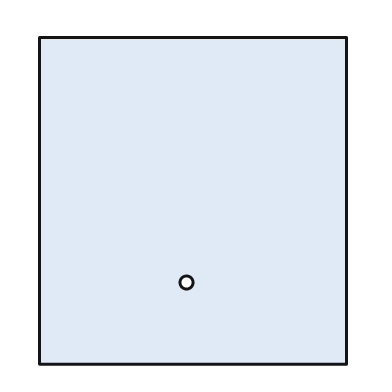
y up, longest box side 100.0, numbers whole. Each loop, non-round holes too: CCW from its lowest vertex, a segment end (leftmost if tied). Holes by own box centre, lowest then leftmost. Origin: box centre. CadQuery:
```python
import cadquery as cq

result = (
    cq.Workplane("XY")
    .moveTo(-47.0, -50.0)
    .lineTo(47.0, -50.0)
    .lineTo(47.0, 50.0)
    .lineTo(-47.0, 50.0)
    .close()
    .moveTo(-2.0, -25.0)
    .circle(2.0)
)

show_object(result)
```